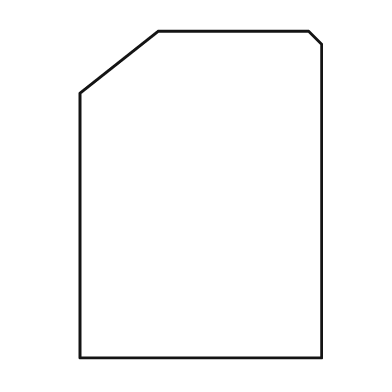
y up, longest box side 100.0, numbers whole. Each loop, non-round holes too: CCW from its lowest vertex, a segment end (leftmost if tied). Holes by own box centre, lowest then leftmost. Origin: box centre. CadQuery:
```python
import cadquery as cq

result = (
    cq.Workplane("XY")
    .moveTo(-37.0, -50.0)
    .lineTo(37.0, -50.0)
    .lineTo(37.0, 46.0)
    .lineTo(33.0, 50.0)
    .lineTo(-13.0, 50.0)
    .lineTo(-37.0, 31.0)
    .close()
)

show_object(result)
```